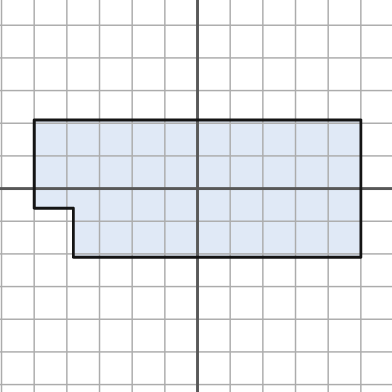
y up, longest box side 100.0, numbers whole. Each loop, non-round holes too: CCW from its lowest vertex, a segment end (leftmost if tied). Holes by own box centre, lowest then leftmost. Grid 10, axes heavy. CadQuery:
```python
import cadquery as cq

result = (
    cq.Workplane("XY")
    .moveTo(-38.0, -21.0)
    .lineTo(50.0, -21.0)
    .lineTo(50.0, 21.0)
    .lineTo(-50.0, 21.0)
    .lineTo(-50.0, -6.0)
    .lineTo(-38.0, -6.0)
    .close()
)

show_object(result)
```